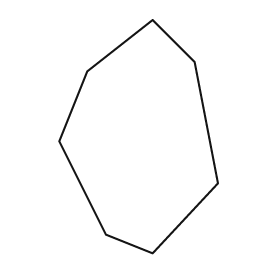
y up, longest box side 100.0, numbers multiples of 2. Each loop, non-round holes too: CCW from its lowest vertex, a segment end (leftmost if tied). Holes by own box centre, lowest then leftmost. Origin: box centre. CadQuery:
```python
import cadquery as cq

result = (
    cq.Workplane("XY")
    .moveTo(6.0, -50.0)
    .lineTo(34.0, -20.0)
    .lineTo(24.0, 32.0)
    .lineTo(6.0, 50.0)
    .lineTo(-22.0, 28.0)
    .lineTo(-34.0, -2.0)
    .lineTo(-14.0, -42.0)
    .close()
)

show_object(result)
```